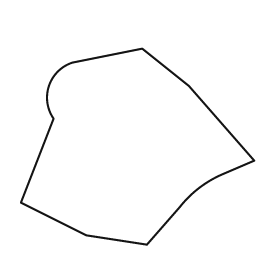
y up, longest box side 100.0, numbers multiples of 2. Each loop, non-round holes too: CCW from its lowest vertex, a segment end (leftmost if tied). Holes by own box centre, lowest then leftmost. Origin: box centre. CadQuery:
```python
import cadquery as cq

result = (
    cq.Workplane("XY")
    .moveTo(4.0, -42.0)
    .lineTo(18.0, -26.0)
    .threePointArc((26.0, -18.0), (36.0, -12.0))
    .lineTo(50.0, -6.0)
    .lineTo(22.0, 26.0)
    .lineTo(2.0, 42.0)
    .lineTo(-28.0, 36.0)
    .threePointArc((-38.0, 26.0), (-36.0, 12.0))
    .lineTo(-50.0, -24.0)
    .lineTo(-22.0, -38.0)
    .close()
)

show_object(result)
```